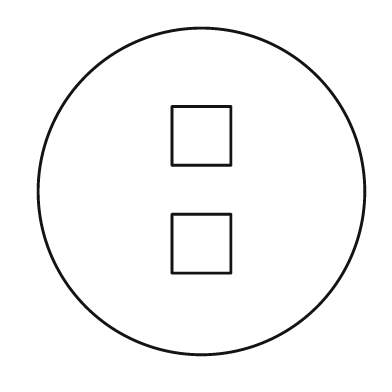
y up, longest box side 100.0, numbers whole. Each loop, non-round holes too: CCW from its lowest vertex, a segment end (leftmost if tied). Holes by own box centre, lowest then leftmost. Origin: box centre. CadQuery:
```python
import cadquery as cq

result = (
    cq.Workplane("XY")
    .moveTo(0.0, 0.0)
    .circle(50.0)
    .moveTo(-9.0, -25.0)
    .lineTo(9.0, -25.0)
    .lineTo(9.0, -7.0)
    .lineTo(-9.0, -7.0)
    .close()
    .moveTo(-9.0, 8.0)
    .lineTo(9.0, 8.0)
    .lineTo(9.0, 26.0)
    .lineTo(-9.0, 26.0)
    .close()
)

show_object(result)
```